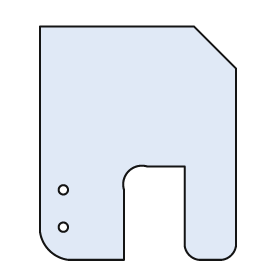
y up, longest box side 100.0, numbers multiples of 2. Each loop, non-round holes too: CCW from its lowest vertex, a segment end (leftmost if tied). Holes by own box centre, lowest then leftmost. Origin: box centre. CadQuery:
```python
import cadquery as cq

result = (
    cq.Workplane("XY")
    .moveTo(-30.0, -50.0)
    .lineTo(-6.0, -50.0)
    .lineTo(-6.0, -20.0)
    .threePointArc((-4.0, -12.0), (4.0, -10.0))
    .lineTo(20.0, -10.0)
    .lineTo(20.0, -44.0)
    .threePointArc((22.0, -48.0), (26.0, -50.0))
    .lineTo(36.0, -50.0)
    .threePointArc((40.0, -48.0), (42.0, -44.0))
    .lineTo(42.0, 32.0)
    .lineTo(24.0, 50.0)
    .lineTo(-42.0, 50.0)
    .lineTo(-42.0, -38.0)
    .threePointArc((-38.0, -46.0), (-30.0, -50.0))
    .close()
    .moveTo(-32.0, -36.0)
    .circle(2.0)
    .moveTo(-32.0, -20.0)
    .circle(2.0)
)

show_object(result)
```